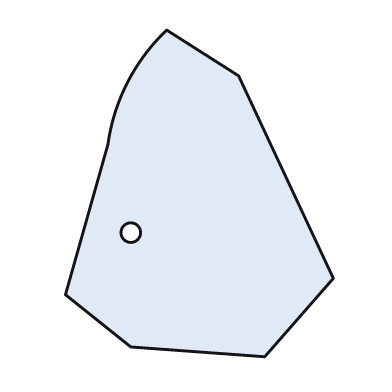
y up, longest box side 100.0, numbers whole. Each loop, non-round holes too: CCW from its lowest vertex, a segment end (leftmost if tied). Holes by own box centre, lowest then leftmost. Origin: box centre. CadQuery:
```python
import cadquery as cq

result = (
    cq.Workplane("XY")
    .moveTo(20.0, -50.0)
    .lineTo(41.0, -26.0)
    .lineTo(12.0, 36.0)
    .lineTo(-10.0, 50.0)
    .threePointArc((-22.0, 34.0), (-28.0, 15.0))
    .lineTo(-41.0, -31.0)
    .lineTo(-21.0, -47.0)
    .close()
    .moveTo(-21.0, -12.0)
    .circle(3.0)
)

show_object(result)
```